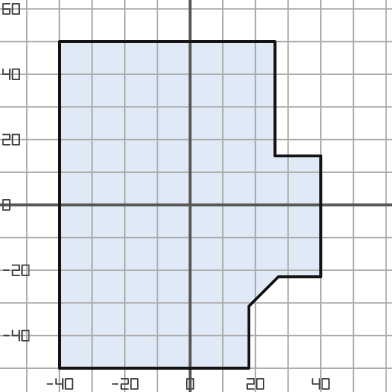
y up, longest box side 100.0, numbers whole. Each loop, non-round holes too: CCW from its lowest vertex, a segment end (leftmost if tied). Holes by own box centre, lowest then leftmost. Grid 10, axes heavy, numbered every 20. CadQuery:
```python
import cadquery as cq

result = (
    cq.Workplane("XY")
    .moveTo(-40.0, -50.0)
    .lineTo(18.0, -50.0)
    .lineTo(18.0, -31.0)
    .lineTo(27.0, -22.0)
    .lineTo(40.0, -22.0)
    .lineTo(40.0, 15.0)
    .lineTo(26.0, 15.0)
    .lineTo(26.0, 50.0)
    .lineTo(-40.0, 50.0)
    .close()
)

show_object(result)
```